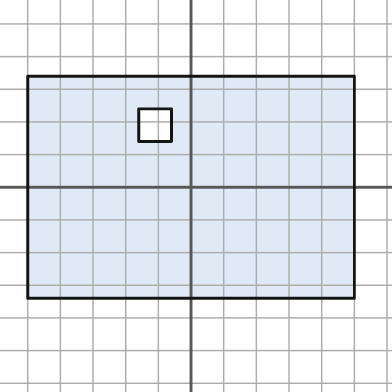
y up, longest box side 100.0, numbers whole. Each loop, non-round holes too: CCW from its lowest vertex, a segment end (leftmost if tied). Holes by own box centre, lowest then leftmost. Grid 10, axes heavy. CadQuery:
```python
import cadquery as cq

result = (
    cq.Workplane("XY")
    .moveTo(-50.0, -34.0)
    .lineTo(50.0, -34.0)
    .lineTo(50.0, 34.0)
    .lineTo(-50.0, 34.0)
    .close()
    .moveTo(-16.0, 14.0)
    .lineTo(-6.0, 14.0)
    .lineTo(-6.0, 24.0)
    .lineTo(-16.0, 24.0)
    .close()
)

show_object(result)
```